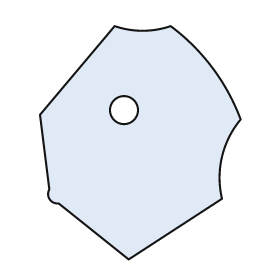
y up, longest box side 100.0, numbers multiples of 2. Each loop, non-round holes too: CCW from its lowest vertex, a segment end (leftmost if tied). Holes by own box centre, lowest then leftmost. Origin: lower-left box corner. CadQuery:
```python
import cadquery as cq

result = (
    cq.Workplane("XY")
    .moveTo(38.0, 0.0)
    .lineTo(78.0, 26.0)
    .threePointArc((78.0, 44.0), (86.0, 60.0))
    .threePointArc((74.0, 82.0), (56.0, 100.0))
    .threePointArc((44.0, 98.0), (32.0, 100.0))
    .lineTo(0.0, 62.0)
    .lineTo(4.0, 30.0)
    .threePointArc((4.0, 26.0), (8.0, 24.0))
    .close()
    .moveTo(36.0, 64.0)
    .circle(6.0)
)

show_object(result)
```